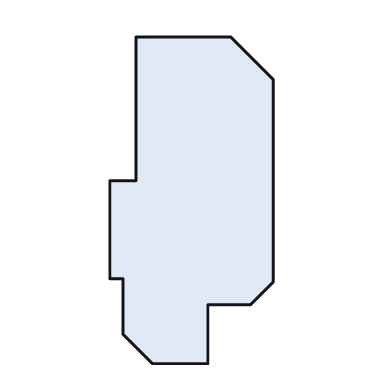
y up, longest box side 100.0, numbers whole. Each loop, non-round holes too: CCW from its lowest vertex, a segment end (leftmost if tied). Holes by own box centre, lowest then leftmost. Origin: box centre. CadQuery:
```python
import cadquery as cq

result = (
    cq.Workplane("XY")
    .moveTo(-12.0, -50.0)
    .lineTo(5.0, -50.0)
    .lineTo(5.0, -32.0)
    .lineTo(18.0, -32.0)
    .lineTo(25.0, -25.0)
    .lineTo(25.0, 37.0)
    .lineTo(12.0, 50.0)
    .lineTo(-17.0, 50.0)
    .lineTo(-17.0, 6.0)
    .lineTo(-25.0, 6.0)
    .lineTo(-25.0, -24.0)
    .lineTo(-21.0, -24.0)
    .lineTo(-21.0, -41.0)
    .close()
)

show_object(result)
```